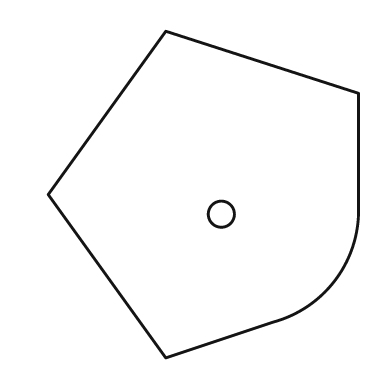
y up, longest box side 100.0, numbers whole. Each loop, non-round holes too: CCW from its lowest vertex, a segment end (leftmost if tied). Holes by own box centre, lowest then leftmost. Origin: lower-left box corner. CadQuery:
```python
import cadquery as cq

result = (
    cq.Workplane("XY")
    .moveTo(36.0, 0.0)
    .lineTo(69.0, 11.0)
    .threePointArc((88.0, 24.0), (95.0, 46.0))
    .lineTo(95.0, 81.0)
    .lineTo(36.0, 100.0)
    .lineTo(0.0, 50.0)
    .close()
    .moveTo(53.0, 44.0)
    .circle(4.0)
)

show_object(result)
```